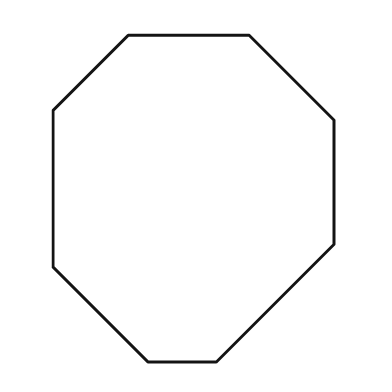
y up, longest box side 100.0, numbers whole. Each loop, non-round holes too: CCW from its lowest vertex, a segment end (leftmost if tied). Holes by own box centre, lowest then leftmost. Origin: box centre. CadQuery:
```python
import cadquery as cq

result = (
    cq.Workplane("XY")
    .moveTo(-14.0, -50.0)
    .lineTo(7.0, -50.0)
    .lineTo(43.0, -14.0)
    .lineTo(43.0, 24.0)
    .lineTo(17.0, 50.0)
    .lineTo(-20.0, 50.0)
    .lineTo(-43.0, 27.0)
    .lineTo(-43.0, -21.0)
    .close()
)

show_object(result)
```